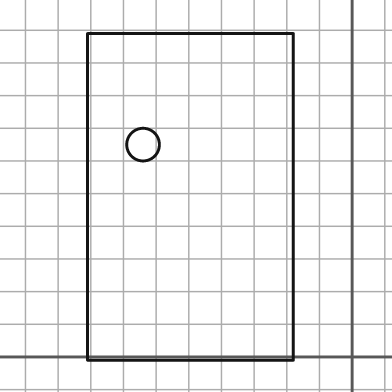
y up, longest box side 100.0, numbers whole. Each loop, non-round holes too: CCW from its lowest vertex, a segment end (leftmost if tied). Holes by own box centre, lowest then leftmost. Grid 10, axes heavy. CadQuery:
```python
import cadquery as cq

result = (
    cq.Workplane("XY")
    .moveTo(-81.0, -1.0)
    .lineTo(-18.0, -1.0)
    .lineTo(-18.0, 99.0)
    .lineTo(-81.0, 99.0)
    .close()
    .moveTo(-64.0, 65.0)
    .circle(5.0)
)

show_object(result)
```